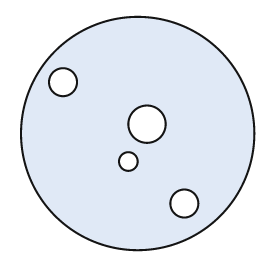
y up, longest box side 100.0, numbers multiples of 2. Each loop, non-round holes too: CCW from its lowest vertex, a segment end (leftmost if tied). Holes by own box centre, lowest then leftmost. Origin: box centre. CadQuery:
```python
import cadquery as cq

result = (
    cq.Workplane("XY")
    .moveTo(0.0, 0.0)
    .circle(50.0)
    .moveTo(20.0, -30.0)
    .circle(6.0)
    .moveTo(-4.0, -12.0)
    .circle(4.0)
    .moveTo(4.0, 4.0)
    .circle(8.0)
    .moveTo(-32.0, 22.0)
    .circle(6.0)
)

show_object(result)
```